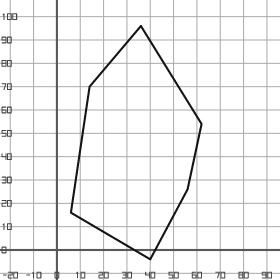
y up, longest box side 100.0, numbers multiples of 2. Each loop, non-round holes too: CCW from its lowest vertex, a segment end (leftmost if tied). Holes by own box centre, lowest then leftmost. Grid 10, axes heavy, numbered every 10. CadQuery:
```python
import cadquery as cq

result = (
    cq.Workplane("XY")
    .moveTo(40.0, -4.0)
    .lineTo(56.0, 26.0)
    .lineTo(62.0, 54.0)
    .lineTo(36.0, 96.0)
    .lineTo(14.0, 70.0)
    .lineTo(6.0, 16.0)
    .close()
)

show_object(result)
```